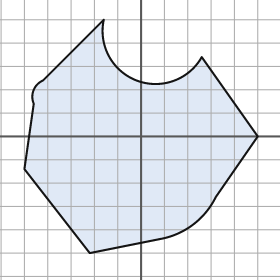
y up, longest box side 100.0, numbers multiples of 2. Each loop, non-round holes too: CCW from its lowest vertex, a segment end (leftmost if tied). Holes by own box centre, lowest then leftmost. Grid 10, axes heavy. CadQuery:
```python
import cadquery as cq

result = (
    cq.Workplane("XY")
    .moveTo(-22.0, -50.0)
    .lineTo(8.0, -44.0)
    .threePointArc((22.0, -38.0), (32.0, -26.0))
    .lineTo(50.0, 0.0)
    .lineTo(26.0, 34.0)
    .threePointArc((-2.0, 24.0), (-16.0, 50.0))
    .lineTo(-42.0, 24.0)
    .threePointArc((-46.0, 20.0), (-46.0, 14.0))
    .lineTo(-50.0, -14.0)
    .close()
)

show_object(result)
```